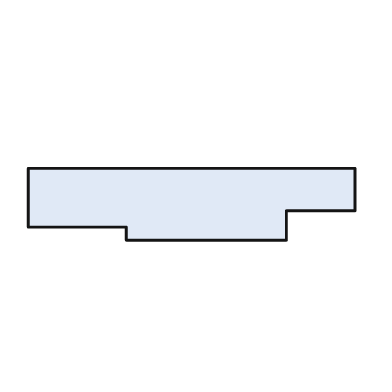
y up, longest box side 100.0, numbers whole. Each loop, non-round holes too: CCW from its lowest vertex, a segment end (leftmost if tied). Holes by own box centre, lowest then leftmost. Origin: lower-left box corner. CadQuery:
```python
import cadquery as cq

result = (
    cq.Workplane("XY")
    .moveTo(30.0, 0.0)
    .lineTo(79.0, 0.0)
    .lineTo(79.0, 9.0)
    .lineTo(100.0, 9.0)
    .lineTo(100.0, 22.0)
    .lineTo(0.0, 22.0)
    .lineTo(0.0, 4.0)
    .lineTo(30.0, 4.0)
    .close()
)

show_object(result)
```